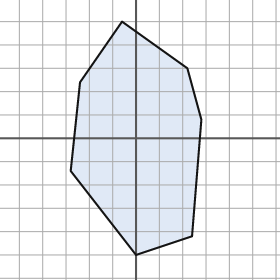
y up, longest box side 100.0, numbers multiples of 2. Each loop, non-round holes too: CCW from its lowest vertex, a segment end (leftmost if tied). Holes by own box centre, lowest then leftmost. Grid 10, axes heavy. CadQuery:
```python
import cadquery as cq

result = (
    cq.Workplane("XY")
    .moveTo(0.0, -50.0)
    .lineTo(24.0, -42.0)
    .lineTo(28.0, 8.0)
    .lineTo(22.0, 30.0)
    .lineTo(-6.0, 50.0)
    .lineTo(-24.0, 24.0)
    .lineTo(-28.0, -14.0)
    .close()
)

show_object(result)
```